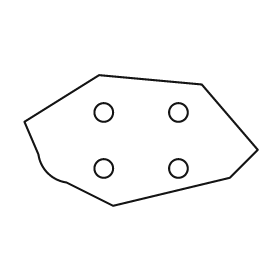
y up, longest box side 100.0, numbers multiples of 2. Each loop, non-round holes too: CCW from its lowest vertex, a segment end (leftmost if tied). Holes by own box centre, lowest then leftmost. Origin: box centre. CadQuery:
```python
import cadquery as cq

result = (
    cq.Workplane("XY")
    .moveTo(-12.0, -28.0)
    .lineTo(38.0, -16.0)
    .lineTo(50.0, -4.0)
    .lineTo(26.0, 24.0)
    .lineTo(-18.0, 28.0)
    .lineTo(-50.0, 8.0)
    .lineTo(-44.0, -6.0)
    .threePointArc((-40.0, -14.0), (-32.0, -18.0))
    .close()
    .moveTo(-16.0, -12.0)
    .circle(4.0)
    .moveTo(16.0, -12.0)
    .circle(4.0)
    .moveTo(-16.0, 12.0)
    .circle(4.0)
    .moveTo(16.0, 12.0)
    .circle(4.0)
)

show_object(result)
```